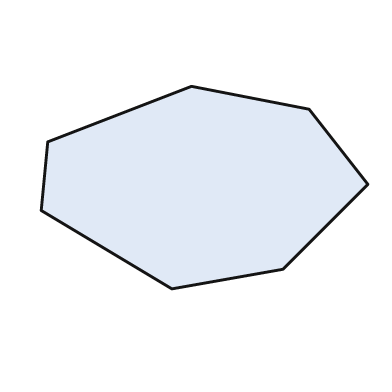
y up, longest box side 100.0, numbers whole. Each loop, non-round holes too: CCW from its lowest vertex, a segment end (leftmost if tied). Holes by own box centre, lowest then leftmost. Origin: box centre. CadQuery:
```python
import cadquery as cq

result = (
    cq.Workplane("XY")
    .moveTo(-10.0, -31.0)
    .lineTo(24.0, -25.0)
    .lineTo(50.0, 1.0)
    .lineTo(32.0, 24.0)
    .lineTo(-4.0, 31.0)
    .lineTo(-48.0, 14.0)
    .lineTo(-50.0, -7.0)
    .close()
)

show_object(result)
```